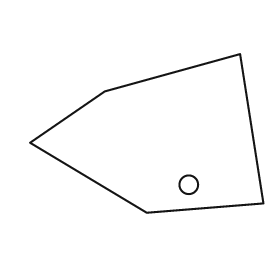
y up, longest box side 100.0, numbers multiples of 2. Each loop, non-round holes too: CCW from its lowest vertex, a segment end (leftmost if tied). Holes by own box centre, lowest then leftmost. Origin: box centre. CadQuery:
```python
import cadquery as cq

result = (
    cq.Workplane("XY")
    .moveTo(0.0, -34.0)
    .lineTo(50.0, -30.0)
    .lineTo(40.0, 34.0)
    .lineTo(-18.0, 18.0)
    .lineTo(-50.0, -4.0)
    .close()
    .moveTo(18.0, -22.0)
    .circle(4.0)
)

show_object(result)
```